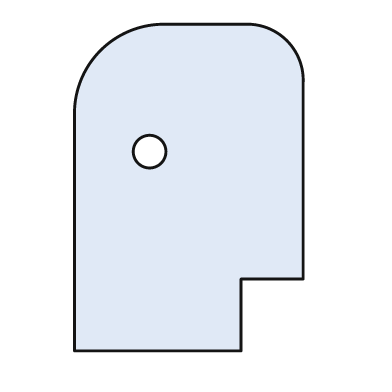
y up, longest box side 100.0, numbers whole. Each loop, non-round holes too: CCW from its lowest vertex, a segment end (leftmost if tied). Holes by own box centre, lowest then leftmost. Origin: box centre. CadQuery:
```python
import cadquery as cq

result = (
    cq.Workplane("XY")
    .moveTo(-35.0, -50.0)
    .lineTo(16.0, -50.0)
    .lineTo(16.0, -28.0)
    .lineTo(35.0, -28.0)
    .lineTo(35.0, 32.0)
    .threePointArc((30.0, 45.0), (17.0, 50.0))
    .lineTo(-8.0, 50.0)
    .threePointArc((-27.0, 42.0), (-35.0, 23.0))
    .close()
    .moveTo(-12.0, 11.0)
    .circle(5.0)
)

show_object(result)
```